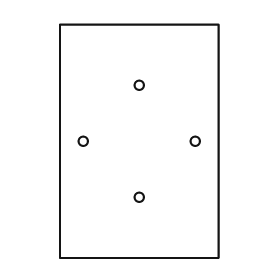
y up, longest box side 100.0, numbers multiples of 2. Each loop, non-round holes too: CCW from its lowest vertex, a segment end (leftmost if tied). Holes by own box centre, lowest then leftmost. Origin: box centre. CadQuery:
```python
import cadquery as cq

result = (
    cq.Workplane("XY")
    .moveTo(-34.0, -50.0)
    .lineTo(34.0, -50.0)
    .lineTo(34.0, 50.0)
    .lineTo(-34.0, 50.0)
    .close()
    .moveTo(0.0, -24.0)
    .circle(2.0)
    .moveTo(-24.0, 0.0)
    .circle(2.0)
    .moveTo(24.0, 0.0)
    .circle(2.0)
    .moveTo(0.0, 24.0)
    .circle(2.0)
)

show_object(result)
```